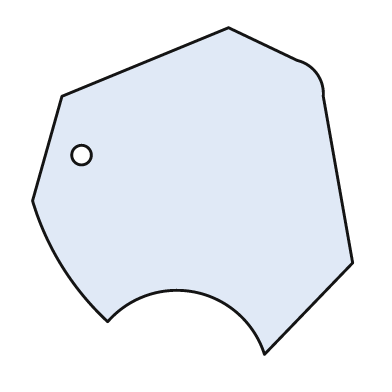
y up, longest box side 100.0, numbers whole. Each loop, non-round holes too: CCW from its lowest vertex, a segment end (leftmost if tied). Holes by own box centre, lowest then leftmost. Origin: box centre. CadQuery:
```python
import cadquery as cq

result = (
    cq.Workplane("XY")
    .moveTo(22.0, -50.0)
    .lineTo(49.0, -22.0)
    .lineTo(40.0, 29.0)
    .threePointArc((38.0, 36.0), (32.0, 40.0))
    .lineTo(11.0, 50.0)
    .lineTo(-40.0, 29.0)
    .lineTo(-49.0, -3.0)
    .threePointArc((-40.0, -23.0), (-26.0, -40.0))
    .threePointArc((1.0, -31.0), (22.0, -50.0))
    .close()
    .moveTo(-34.0, 11.0)
    .circle(3.0)
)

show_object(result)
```